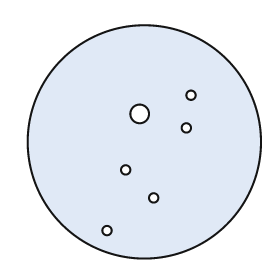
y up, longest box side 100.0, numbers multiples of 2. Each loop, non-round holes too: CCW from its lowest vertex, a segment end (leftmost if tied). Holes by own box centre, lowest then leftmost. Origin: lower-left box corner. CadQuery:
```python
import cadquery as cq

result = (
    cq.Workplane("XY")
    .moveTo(50.0, 50.0)
    .circle(50.0)
    .moveTo(34.0, 12.0)
    .circle(2.0)
    .moveTo(54.0, 26.0)
    .circle(2.0)
    .moveTo(42.0, 38.0)
    .circle(2.0)
    .moveTo(68.0, 56.0)
    .circle(2.0)
    .moveTo(48.0, 62.0)
    .circle(4.0)
    .moveTo(70.0, 70.0)
    .circle(2.0)
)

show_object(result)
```